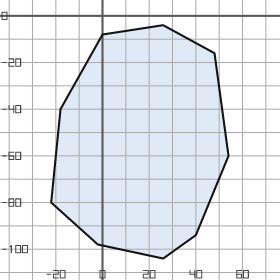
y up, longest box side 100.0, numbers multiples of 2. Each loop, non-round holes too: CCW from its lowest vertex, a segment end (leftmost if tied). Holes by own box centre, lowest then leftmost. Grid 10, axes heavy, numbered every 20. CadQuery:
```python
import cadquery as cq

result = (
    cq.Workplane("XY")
    .moveTo(26.0, -104.0)
    .lineTo(40.0, -94.0)
    .lineTo(54.0, -60.0)
    .lineTo(48.0, -16.0)
    .lineTo(26.0, -4.0)
    .lineTo(0.0, -8.0)
    .lineTo(-18.0, -40.0)
    .lineTo(-22.0, -80.0)
    .lineTo(-2.0, -98.0)
    .close()
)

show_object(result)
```